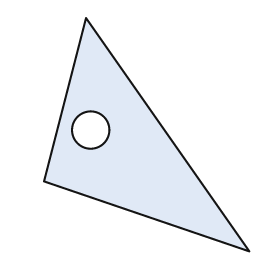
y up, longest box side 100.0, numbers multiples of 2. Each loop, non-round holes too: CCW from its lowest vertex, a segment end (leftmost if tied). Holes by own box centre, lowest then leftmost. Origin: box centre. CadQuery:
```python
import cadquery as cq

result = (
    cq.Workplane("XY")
    .moveTo(44.0, -50.0)
    .lineTo(-26.0, 50.0)
    .lineTo(-44.0, -20.0)
    .close()
    .moveTo(-24.0, 2.0)
    .circle(8.0)
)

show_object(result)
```